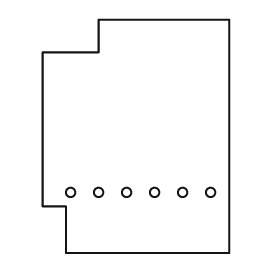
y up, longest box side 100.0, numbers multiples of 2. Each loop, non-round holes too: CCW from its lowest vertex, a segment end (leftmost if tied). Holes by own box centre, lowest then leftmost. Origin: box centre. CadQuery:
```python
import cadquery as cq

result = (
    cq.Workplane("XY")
    .moveTo(-30.0, -50.0)
    .lineTo(40.0, -50.0)
    .lineTo(40.0, 50.0)
    .lineTo(-16.0, 50.0)
    .lineTo(-16.0, 36.0)
    .lineTo(-40.0, 36.0)
    .lineTo(-40.0, -30.0)
    .lineTo(-30.0, -30.0)
    .close()
    .moveTo(-28.0, -24.0)
    .circle(2.0)
    .moveTo(-16.0, -24.0)
    .circle(2.0)
    .moveTo(-4.0, -24.0)
    .circle(2.0)
    .moveTo(8.0, -24.0)
    .circle(2.0)
    .moveTo(20.0, -24.0)
    .circle(2.0)
    .moveTo(32.0, -24.0)
    .circle(2.0)
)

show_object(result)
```